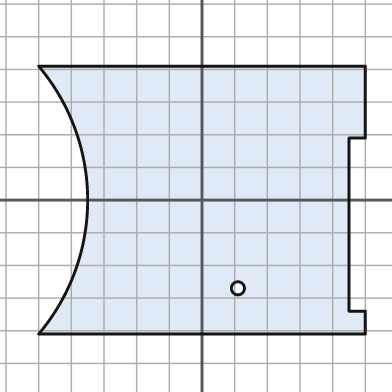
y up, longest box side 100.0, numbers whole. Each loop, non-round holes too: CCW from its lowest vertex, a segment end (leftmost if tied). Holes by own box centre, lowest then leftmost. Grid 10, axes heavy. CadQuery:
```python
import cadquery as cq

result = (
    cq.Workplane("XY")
    .moveTo(-50.0, -41.0)
    .lineTo(50.0, -41.0)
    .lineTo(50.0, -34.0)
    .lineTo(45.0, -34.0)
    .lineTo(45.0, 19.0)
    .lineTo(50.0, 19.0)
    .lineTo(50.0, 41.0)
    .lineTo(-50.0, 41.0)
    .threePointArc((-35.0, 0.0), (-50.0, -41.0))
    .close()
    .moveTo(11.0, -27.0)
    .circle(2.0)
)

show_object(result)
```